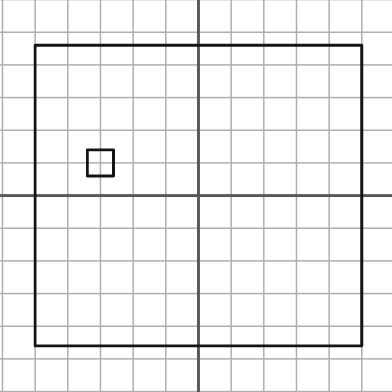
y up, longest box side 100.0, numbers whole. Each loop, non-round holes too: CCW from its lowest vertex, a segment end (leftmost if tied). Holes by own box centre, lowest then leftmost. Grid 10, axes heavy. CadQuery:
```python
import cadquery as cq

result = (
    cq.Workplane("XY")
    .moveTo(-50.0, -46.0)
    .lineTo(50.0, -46.0)
    .lineTo(50.0, 46.0)
    .lineTo(-50.0, 46.0)
    .close()
    .moveTo(-34.0, 6.0)
    .lineTo(-26.0, 6.0)
    .lineTo(-26.0, 14.0)
    .lineTo(-34.0, 14.0)
    .close()
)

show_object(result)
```